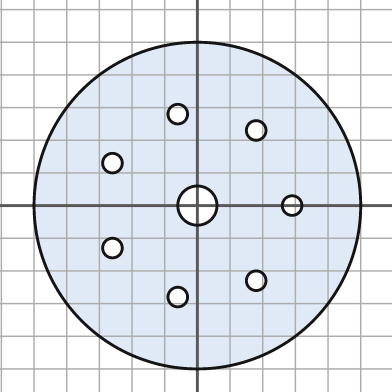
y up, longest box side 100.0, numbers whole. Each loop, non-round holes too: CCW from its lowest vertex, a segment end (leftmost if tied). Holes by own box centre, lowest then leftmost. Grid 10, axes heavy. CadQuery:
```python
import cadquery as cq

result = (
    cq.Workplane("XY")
    .moveTo(0.0, 0.0)
    .circle(50.0)
    .moveTo(-6.0, -28.0)
    .circle(3.0)
    .moveTo(18.0, -23.0)
    .circle(3.0)
    .moveTo(-26.0, -13.0)
    .circle(3.0)
    .moveTo(0.0, 0.0)
    .circle(6.0)
    .moveTo(29.0, 0.0)
    .circle(3.0)
    .moveTo(-26.0, 13.0)
    .circle(3.0)
    .moveTo(18.0, 23.0)
    .circle(3.0)
    .moveTo(-6.0, 28.0)
    .circle(3.0)
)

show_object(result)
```